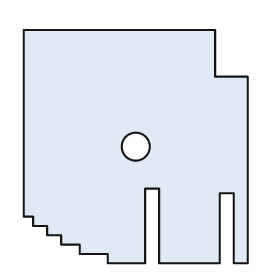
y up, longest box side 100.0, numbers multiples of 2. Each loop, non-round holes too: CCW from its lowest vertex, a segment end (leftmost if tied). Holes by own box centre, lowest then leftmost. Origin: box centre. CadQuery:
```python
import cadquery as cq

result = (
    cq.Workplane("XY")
    .moveTo(-12.0, -50.0)
    .lineTo(4.0, -50.0)
    .lineTo(4.0, -18.0)
    .lineTo(10.0, -18.0)
    .lineTo(10.0, -50.0)
    .lineTo(36.0, -50.0)
    .lineTo(36.0, -20.0)
    .lineTo(42.0, -20.0)
    .lineTo(42.0, -50.0)
    .lineTo(48.0, -50.0)
    .lineTo(48.0, 30.0)
    .lineTo(34.0, 30.0)
    .lineTo(34.0, 50.0)
    .lineTo(-48.0, 50.0)
    .lineTo(-48.0, -30.0)
    .lineTo(-44.0, -30.0)
    .lineTo(-44.0, -34.0)
    .lineTo(-38.0, -34.0)
    .lineTo(-38.0, -38.0)
    .lineTo(-32.0, -38.0)
    .lineTo(-32.0, -42.0)
    .lineTo(-24.0, -42.0)
    .lineTo(-24.0, -46.0)
    .lineTo(-12.0, -46.0)
    .close()
    .moveTo(0.0, 0.0)
    .circle(6.0)
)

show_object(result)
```